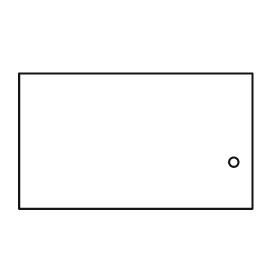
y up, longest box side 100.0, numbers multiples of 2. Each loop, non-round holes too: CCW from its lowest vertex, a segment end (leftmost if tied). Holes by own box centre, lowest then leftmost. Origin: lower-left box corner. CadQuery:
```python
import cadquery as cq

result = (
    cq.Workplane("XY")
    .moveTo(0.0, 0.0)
    .lineTo(100.0, 0.0)
    .lineTo(100.0, 58.0)
    .lineTo(0.0, 58.0)
    .close()
    .moveTo(92.0, 20.0)
    .circle(2.0)
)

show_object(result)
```